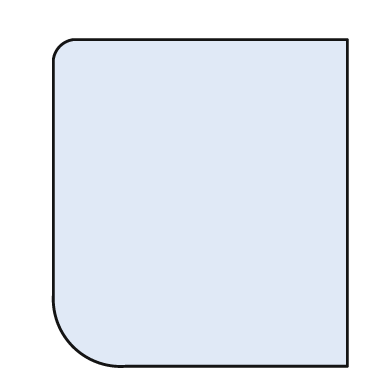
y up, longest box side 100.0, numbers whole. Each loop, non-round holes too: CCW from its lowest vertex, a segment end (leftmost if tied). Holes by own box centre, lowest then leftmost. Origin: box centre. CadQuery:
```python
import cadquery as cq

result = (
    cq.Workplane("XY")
    .moveTo(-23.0, -50.0)
    .lineTo(45.0, -50.0)
    .lineTo(45.0, 50.0)
    .lineTo(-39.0, 50.0)
    .threePointArc((-43.0, 48.0), (-45.0, 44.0))
    .lineTo(-45.0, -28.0)
    .threePointArc((-39.0, -44.0), (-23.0, -50.0))
    .close()
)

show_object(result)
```